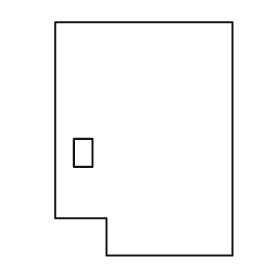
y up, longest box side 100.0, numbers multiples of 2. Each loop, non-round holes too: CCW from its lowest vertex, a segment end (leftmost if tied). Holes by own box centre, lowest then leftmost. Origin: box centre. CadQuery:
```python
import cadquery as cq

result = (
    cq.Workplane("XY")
    .moveTo(-16.0, -50.0)
    .lineTo(38.0, -50.0)
    .lineTo(38.0, 50.0)
    .lineTo(-38.0, 50.0)
    .lineTo(-38.0, -34.0)
    .lineTo(-16.0, -34.0)
    .close()
    .moveTo(-30.0, -12.0)
    .lineTo(-22.0, -12.0)
    .lineTo(-22.0, 0.0)
    .lineTo(-30.0, 0.0)
    .close()
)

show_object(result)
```